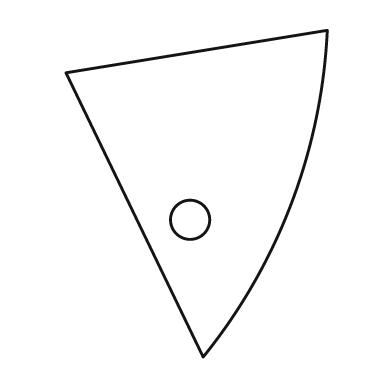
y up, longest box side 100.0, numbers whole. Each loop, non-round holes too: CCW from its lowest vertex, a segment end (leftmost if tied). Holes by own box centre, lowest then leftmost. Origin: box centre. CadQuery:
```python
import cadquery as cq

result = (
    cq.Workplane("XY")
    .moveTo(2.0, -50.0)
    .threePointArc((29.0, -3.0), (40.0, 50.0))
    .lineTo(-40.0, 37.0)
    .close()
    .moveTo(-2.0, -8.0)
    .circle(6.0)
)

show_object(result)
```